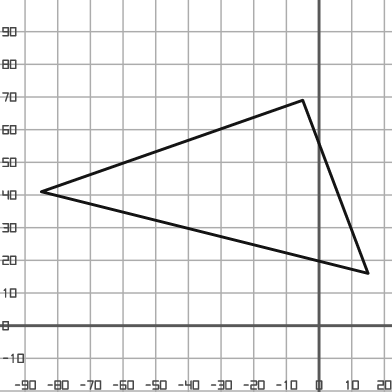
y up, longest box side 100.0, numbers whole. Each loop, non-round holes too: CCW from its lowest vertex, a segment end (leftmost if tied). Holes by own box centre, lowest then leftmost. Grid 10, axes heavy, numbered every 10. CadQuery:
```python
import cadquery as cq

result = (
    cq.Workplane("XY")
    .moveTo(15.0, 16.0)
    .lineTo(-5.0, 69.0)
    .lineTo(-85.0, 41.0)
    .close()
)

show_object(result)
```